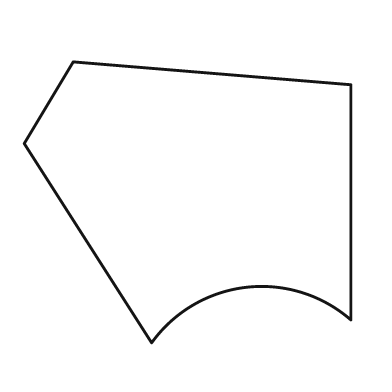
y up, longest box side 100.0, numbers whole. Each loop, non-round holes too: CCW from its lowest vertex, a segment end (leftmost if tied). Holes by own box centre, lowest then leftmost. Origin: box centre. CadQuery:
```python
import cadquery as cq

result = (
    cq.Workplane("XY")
    .moveTo(-11.0, -43.0)
    .threePointArc((18.0, -26.0), (50.0, -36.0))
    .lineTo(50.0, 36.0)
    .lineTo(-35.0, 43.0)
    .lineTo(-50.0, 18.0)
    .close()
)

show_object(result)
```